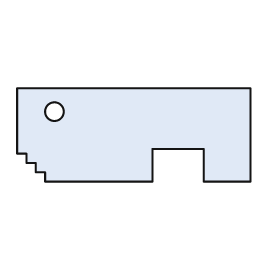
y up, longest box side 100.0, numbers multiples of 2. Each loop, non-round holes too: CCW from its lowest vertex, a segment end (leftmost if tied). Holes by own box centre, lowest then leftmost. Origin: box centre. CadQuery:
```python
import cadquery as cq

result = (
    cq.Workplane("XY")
    .moveTo(-38.0, -20.0)
    .lineTo(8.0, -20.0)
    .lineTo(8.0, -6.0)
    .lineTo(30.0, -6.0)
    .lineTo(30.0, -20.0)
    .lineTo(50.0, -20.0)
    .lineTo(50.0, 20.0)
    .lineTo(-50.0, 20.0)
    .lineTo(-50.0, -8.0)
    .lineTo(-46.0, -8.0)
    .lineTo(-46.0, -12.0)
    .lineTo(-42.0, -12.0)
    .lineTo(-42.0, -16.0)
    .lineTo(-38.0, -16.0)
    .close()
    .moveTo(-34.0, 10.0)
    .circle(4.0)
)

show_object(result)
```